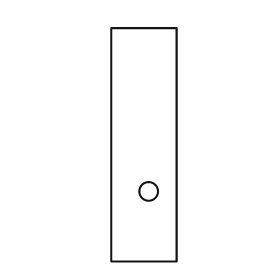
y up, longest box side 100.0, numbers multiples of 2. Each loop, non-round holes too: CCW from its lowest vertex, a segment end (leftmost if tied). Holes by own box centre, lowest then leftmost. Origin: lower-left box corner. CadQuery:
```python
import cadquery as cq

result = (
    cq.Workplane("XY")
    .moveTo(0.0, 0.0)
    .lineTo(28.0, 0.0)
    .lineTo(28.0, 100.0)
    .lineTo(0.0, 100.0)
    .close()
    .moveTo(16.0, 30.0)
    .circle(4.0)
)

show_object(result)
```